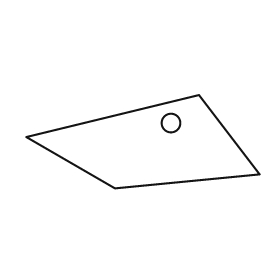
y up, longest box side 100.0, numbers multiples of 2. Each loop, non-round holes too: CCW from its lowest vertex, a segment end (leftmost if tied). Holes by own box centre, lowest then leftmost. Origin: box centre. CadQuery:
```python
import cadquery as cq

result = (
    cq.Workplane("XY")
    .moveTo(-12.0, -20.0)
    .lineTo(50.0, -14.0)
    .lineTo(24.0, 20.0)
    .lineTo(-50.0, 2.0)
    .close()
    .moveTo(12.0, 8.0)
    .circle(4.0)
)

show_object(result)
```